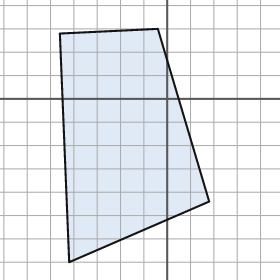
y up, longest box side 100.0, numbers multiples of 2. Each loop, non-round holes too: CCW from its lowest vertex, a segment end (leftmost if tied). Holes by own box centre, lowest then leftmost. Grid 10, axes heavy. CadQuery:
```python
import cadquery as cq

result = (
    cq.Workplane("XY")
    .moveTo(-42.0, -70.0)
    .lineTo(18.0, -44.0)
    .lineTo(-4.0, 30.0)
    .lineTo(-46.0, 28.0)
    .close()
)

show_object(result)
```